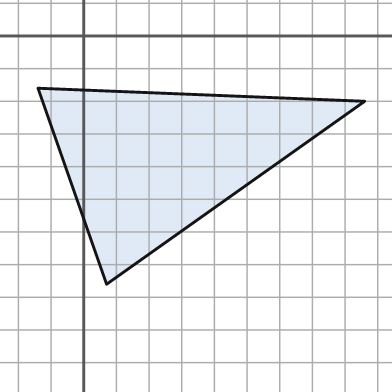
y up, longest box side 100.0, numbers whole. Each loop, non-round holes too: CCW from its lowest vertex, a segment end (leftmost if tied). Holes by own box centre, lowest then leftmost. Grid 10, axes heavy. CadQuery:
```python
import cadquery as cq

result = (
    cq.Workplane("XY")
    .moveTo(7.0, -76.0)
    .lineTo(86.0, -20.0)
    .lineTo(-14.0, -16.0)
    .close()
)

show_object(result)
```